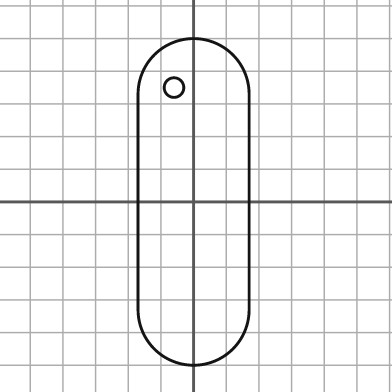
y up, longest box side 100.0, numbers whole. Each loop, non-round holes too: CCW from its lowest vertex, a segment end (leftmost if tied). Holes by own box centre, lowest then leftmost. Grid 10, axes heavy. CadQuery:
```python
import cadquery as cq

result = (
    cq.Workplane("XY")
    .moveTo(-17.0, -33.0)
    .threePointArc((0.0, -50.0), (17.0, -33.0))
    .lineTo(17.0, 33.0)
    .threePointArc((0.0, 50.0), (-17.0, 33.0))
    .close()
    .moveTo(-6.0, 35.0)
    .circle(3.0)
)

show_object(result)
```